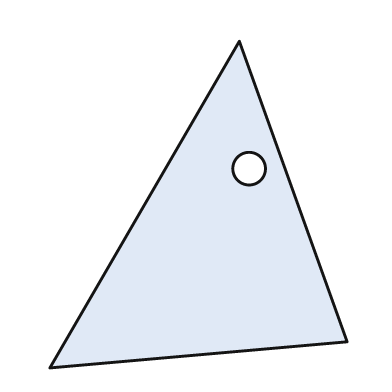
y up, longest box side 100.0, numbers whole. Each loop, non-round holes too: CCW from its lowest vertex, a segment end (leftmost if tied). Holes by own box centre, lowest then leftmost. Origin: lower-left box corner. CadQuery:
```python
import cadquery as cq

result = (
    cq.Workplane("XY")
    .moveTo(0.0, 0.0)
    .lineTo(91.0, 8.0)
    .lineTo(58.0, 100.0)
    .close()
    .moveTo(61.0, 61.0)
    .circle(5.0)
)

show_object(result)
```